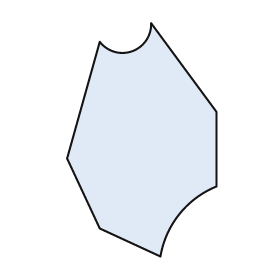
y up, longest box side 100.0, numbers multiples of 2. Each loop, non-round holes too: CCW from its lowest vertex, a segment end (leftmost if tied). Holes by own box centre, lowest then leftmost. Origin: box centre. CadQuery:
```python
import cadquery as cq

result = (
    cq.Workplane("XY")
    .moveTo(8.0, -50.0)
    .threePointArc((16.0, -32.0), (32.0, -20.0))
    .lineTo(32.0, 12.0)
    .lineTo(4.0, 50.0)
    .threePointArc((-4.0, 38.0), (-18.0, 42.0))
    .lineTo(-32.0, -8.0)
    .lineTo(-18.0, -38.0)
    .close()
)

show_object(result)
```